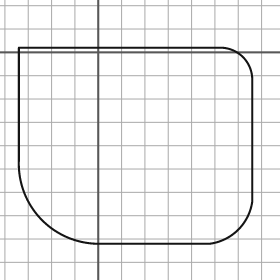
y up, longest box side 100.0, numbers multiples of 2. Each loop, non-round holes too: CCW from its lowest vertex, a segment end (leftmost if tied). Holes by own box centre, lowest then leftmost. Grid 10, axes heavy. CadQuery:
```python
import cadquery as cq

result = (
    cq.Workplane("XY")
    .moveTo(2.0, -82.0)
    .lineTo(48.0, -82.0)
    .threePointArc((60.0, -76.0), (66.0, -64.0))
    .lineTo(66.0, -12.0)
    .threePointArc((62.0, -2.0), (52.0, 2.0))
    .lineTo(-34.0, 2.0)
    .lineTo(-34.0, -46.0)
    .threePointArc((-24.0, -72.0), (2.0, -82.0))
    .close()
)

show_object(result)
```